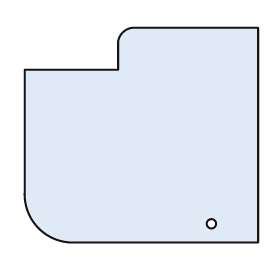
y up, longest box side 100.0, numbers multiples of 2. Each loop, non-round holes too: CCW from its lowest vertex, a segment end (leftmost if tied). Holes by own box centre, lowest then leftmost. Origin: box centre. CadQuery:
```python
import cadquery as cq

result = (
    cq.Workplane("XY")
    .moveTo(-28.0, -46.0)
    .lineTo(50.0, -46.0)
    .lineTo(50.0, 46.0)
    .lineTo(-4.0, 46.0)
    .threePointArc((-8.0, 44.0), (-10.0, 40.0))
    .lineTo(-10.0, 28.0)
    .lineTo(-50.0, 28.0)
    .lineTo(-50.0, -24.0)
    .threePointArc((-44.0, -40.0), (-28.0, -46.0))
    .close()
    .moveTo(30.0, -38.0)
    .circle(2.0)
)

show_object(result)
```